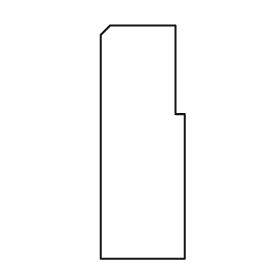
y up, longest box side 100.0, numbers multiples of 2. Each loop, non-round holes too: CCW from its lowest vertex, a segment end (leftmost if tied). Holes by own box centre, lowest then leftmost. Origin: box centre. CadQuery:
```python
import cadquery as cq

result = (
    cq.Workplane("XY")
    .moveTo(-18.0, -50.0)
    .lineTo(18.0, -50.0)
    .lineTo(18.0, 12.0)
    .lineTo(14.0, 12.0)
    .lineTo(14.0, 50.0)
    .lineTo(-14.0, 50.0)
    .lineTo(-18.0, 46.0)
    .close()
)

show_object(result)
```